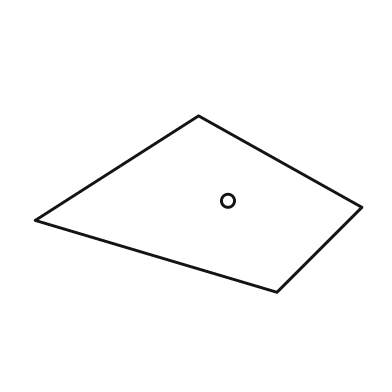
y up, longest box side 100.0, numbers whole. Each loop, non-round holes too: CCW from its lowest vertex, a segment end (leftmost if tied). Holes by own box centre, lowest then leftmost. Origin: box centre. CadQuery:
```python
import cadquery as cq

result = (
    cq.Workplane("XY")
    .moveTo(24.0, -27.0)
    .lineTo(50.0, -1.0)
    .lineTo(0.0, 27.0)
    .lineTo(-50.0, -5.0)
    .close()
    .moveTo(9.0, 1.0)
    .circle(2.0)
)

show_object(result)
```